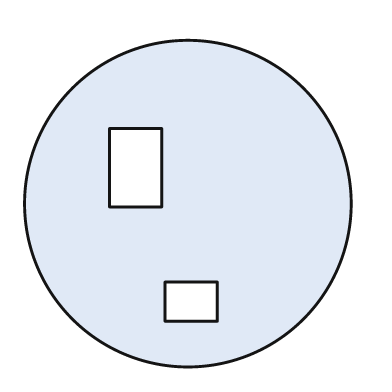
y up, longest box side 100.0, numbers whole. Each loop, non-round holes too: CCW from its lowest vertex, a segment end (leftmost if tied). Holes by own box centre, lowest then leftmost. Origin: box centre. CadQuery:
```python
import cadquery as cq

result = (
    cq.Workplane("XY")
    .moveTo(0.0, 0.0)
    .circle(50.0)
    .moveTo(-7.0, -36.0)
    .lineTo(9.0, -36.0)
    .lineTo(9.0, -24.0)
    .lineTo(-7.0, -24.0)
    .close()
    .moveTo(-24.0, -1.0)
    .lineTo(-8.0, -1.0)
    .lineTo(-8.0, 23.0)
    .lineTo(-24.0, 23.0)
    .close()
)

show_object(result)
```